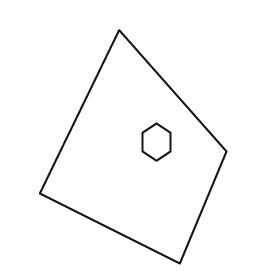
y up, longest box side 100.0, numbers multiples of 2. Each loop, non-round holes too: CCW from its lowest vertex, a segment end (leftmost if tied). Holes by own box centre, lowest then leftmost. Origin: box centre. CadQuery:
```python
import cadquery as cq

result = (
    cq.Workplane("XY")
    .moveTo(20.0, -50.0)
    .lineTo(40.0, -2.0)
    .lineTo(-6.0, 50.0)
    .lineTo(-40.0, -20.0)
    .close()
    .moveTo(10.0, -6.0)
    .lineTo(16.0, -2.0)
    .lineTo(16.0, 6.0)
    .lineTo(10.0, 10.0)
    .lineTo(4.0, 6.0)
    .lineTo(4.0, -2.0)
    .close()
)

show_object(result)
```